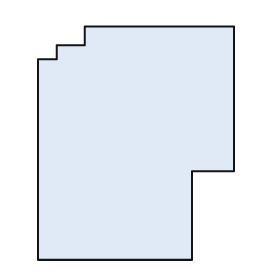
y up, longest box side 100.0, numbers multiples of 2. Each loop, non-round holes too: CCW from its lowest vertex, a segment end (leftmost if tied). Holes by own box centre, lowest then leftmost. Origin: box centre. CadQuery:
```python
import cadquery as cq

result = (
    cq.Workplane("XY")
    .moveTo(-42.0, -50.0)
    .lineTo(24.0, -50.0)
    .lineTo(24.0, -12.0)
    .lineTo(42.0, -12.0)
    .lineTo(42.0, 50.0)
    .lineTo(-22.0, 50.0)
    .lineTo(-22.0, 42.0)
    .lineTo(-34.0, 42.0)
    .lineTo(-34.0, 36.0)
    .lineTo(-42.0, 36.0)
    .close()
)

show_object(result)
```